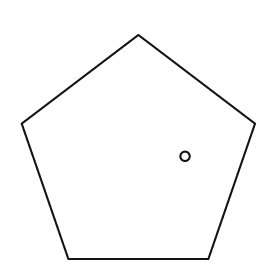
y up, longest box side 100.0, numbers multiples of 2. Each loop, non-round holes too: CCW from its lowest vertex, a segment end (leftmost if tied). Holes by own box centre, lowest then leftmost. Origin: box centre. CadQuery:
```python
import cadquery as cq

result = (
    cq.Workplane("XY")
    .moveTo(-30.0, -48.0)
    .lineTo(30.0, -48.0)
    .lineTo(50.0, 10.0)
    .lineTo(0.0, 48.0)
    .lineTo(-50.0, 10.0)
    .close()
    .moveTo(20.0, -4.0)
    .circle(2.0)
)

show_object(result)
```